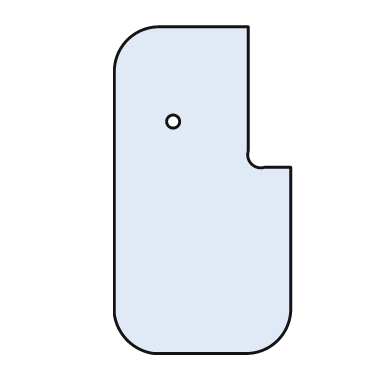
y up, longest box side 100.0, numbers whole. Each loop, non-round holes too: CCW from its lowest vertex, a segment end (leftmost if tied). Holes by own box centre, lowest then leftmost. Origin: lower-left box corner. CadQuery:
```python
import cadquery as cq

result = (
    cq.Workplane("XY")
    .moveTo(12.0, 0.0)
    .lineTo(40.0, 0.0)
    .threePointArc((50.0, 4.0), (54.0, 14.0))
    .lineTo(54.0, 57.0)
    .lineTo(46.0, 57.0)
    .threePointArc((42.0, 58.0), (41.0, 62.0))
    .lineTo(41.0, 100.0)
    .lineTo(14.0, 100.0)
    .threePointArc((4.0, 96.0), (0.0, 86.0))
    .lineTo(0.0, 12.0)
    .threePointArc((4.0, 4.0), (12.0, 0.0))
    .close()
    .moveTo(18.0, 71.0)
    .circle(2.0)
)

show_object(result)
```